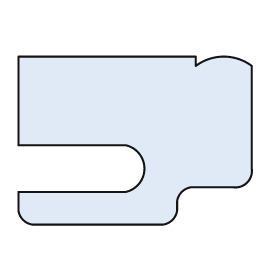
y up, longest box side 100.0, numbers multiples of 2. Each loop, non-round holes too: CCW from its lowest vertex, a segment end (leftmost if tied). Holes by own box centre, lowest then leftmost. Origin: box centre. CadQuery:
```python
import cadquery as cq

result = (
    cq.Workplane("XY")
    .moveTo(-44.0, -36.0)
    .lineTo(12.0, -36.0)
    .threePointArc((16.0, -34.0), (18.0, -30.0))
    .lineTo(18.0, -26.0)
    .threePointArc((20.0, -22.0), (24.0, -20.0))
    .lineTo(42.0, -20.0)
    .threePointArc((48.0, -18.0), (50.0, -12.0))
    .lineTo(50.0, 32.0)
    .threePointArc((38.0, 36.0), (26.0, 32.0))
    .lineTo(26.0, 36.0)
    .lineTo(-50.0, 36.0)
    .lineTo(-50.0, -2.0)
    .lineTo(-4.0, -2.0)
    .threePointArc((4.0, -12.0), (-4.0, -22.0))
    .lineTo(-50.0, -22.0)
    .lineTo(-50.0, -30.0)
    .threePointArc((-48.0, -34.0), (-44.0, -36.0))
    .close()
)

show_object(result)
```